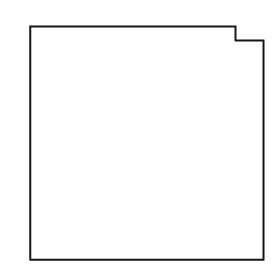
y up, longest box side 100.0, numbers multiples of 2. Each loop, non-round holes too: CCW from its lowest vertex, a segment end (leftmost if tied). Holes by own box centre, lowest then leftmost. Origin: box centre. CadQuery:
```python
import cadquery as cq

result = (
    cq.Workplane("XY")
    .moveTo(-50.0, -50.0)
    .lineTo(50.0, -50.0)
    .lineTo(50.0, 44.0)
    .lineTo(38.0, 44.0)
    .lineTo(38.0, 50.0)
    .lineTo(-50.0, 50.0)
    .close()
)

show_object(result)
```